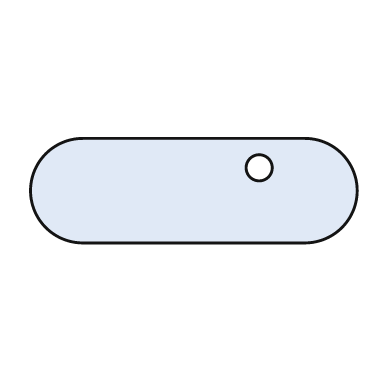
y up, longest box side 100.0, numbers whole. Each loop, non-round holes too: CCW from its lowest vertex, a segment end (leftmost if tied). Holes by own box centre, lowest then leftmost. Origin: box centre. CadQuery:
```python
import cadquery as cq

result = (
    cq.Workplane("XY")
    .moveTo(-34.0, -16.0)
    .lineTo(34.0, -16.0)
    .threePointArc((50.0, 0.0), (34.0, 16.0))
    .lineTo(-34.0, 16.0)
    .threePointArc((-50.0, 0.0), (-34.0, -16.0))
    .close()
    .moveTo(20.0, 7.0)
    .circle(4.0)
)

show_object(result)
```